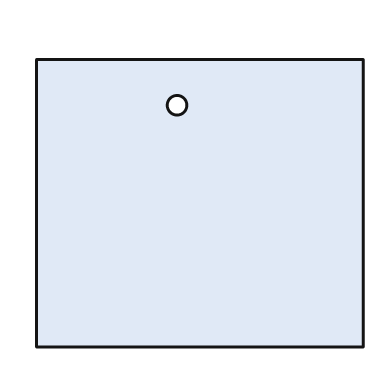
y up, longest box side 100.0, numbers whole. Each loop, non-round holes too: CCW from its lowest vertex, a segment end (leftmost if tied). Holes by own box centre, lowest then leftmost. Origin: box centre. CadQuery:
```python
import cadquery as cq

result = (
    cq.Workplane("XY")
    .moveTo(-50.0, -44.0)
    .lineTo(50.0, -44.0)
    .lineTo(50.0, 44.0)
    .lineTo(-50.0, 44.0)
    .close()
    .moveTo(-7.0, 30.0)
    .circle(3.0)
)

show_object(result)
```